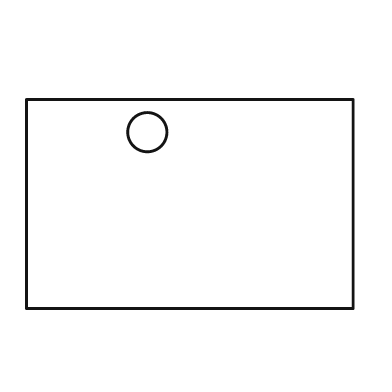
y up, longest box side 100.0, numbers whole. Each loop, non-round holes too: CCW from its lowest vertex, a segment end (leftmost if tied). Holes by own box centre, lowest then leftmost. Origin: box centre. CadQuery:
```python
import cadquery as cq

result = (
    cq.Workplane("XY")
    .moveTo(-50.0, -32.0)
    .lineTo(50.0, -32.0)
    .lineTo(50.0, 32.0)
    .lineTo(-50.0, 32.0)
    .close()
    .moveTo(-13.0, 22.0)
    .circle(6.0)
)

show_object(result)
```